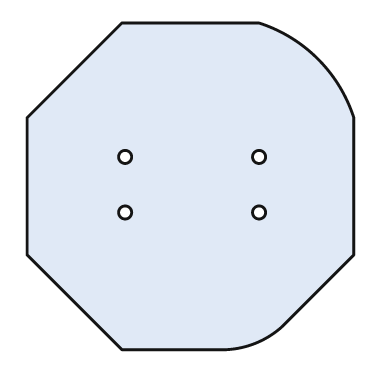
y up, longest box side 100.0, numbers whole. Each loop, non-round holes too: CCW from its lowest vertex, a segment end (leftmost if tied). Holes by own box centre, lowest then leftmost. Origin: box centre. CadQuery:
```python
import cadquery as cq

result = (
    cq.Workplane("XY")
    .moveTo(-21.0, -50.0)
    .lineTo(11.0, -50.0)
    .threePointArc((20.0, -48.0), (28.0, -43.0))
    .lineTo(50.0, -21.0)
    .lineTo(50.0, 21.0)
    .threePointArc((39.0, 39.0), (21.0, 50.0))
    .lineTo(-21.0, 50.0)
    .lineTo(-50.0, 21.0)
    .lineTo(-50.0, -21.0)
    .close()
    .moveTo(-20.0, -8.0)
    .circle(2.0)
    .moveTo(21.0, -8.0)
    .circle(2.0)
    .moveTo(-20.0, 9.0)
    .circle(2.0)
    .moveTo(21.0, 9.0)
    .circle(2.0)
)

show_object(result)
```